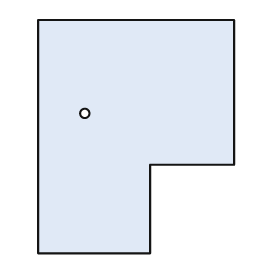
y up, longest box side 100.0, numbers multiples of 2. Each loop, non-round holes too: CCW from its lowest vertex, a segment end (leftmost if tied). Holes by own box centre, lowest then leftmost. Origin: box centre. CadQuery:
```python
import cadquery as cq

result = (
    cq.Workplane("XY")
    .moveTo(-42.0, -50.0)
    .lineTo(6.0, -50.0)
    .lineTo(6.0, -12.0)
    .lineTo(42.0, -12.0)
    .lineTo(42.0, 50.0)
    .lineTo(-42.0, 50.0)
    .close()
    .moveTo(-22.0, 10.0)
    .circle(2.0)
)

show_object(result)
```